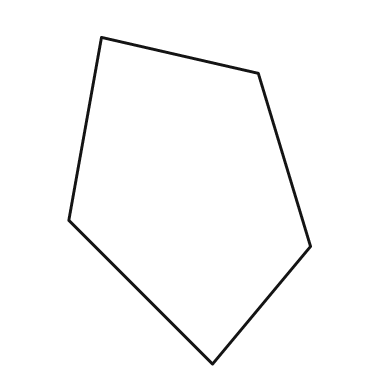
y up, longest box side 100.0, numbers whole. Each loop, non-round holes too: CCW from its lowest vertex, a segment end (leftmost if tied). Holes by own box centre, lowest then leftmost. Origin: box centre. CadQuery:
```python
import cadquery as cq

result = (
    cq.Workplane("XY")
    .moveTo(7.0, -50.0)
    .lineTo(37.0, -14.0)
    .lineTo(21.0, 39.0)
    .lineTo(-27.0, 50.0)
    .lineTo(-37.0, -6.0)
    .close()
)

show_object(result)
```